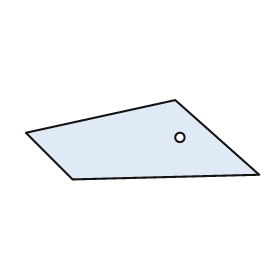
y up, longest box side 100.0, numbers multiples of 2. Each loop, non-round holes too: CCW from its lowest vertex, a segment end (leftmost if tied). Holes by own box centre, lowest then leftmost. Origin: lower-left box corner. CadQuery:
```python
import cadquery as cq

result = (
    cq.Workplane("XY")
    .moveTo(20.0, 0.0)
    .lineTo(100.0, 2.0)
    .lineTo(64.0, 34.0)
    .lineTo(0.0, 20.0)
    .close()
    .moveTo(66.0, 18.0)
    .circle(2.0)
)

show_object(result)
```